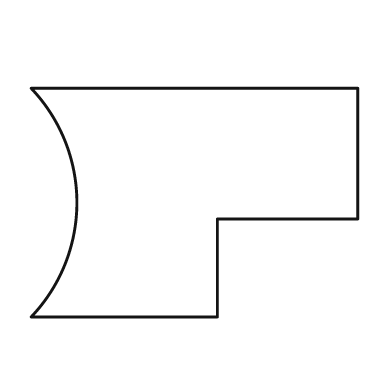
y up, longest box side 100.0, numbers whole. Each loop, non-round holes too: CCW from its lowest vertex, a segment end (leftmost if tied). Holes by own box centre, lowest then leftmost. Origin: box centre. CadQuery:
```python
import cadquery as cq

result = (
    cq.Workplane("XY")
    .moveTo(-50.0, -35.0)
    .lineTo(7.0, -35.0)
    .lineTo(7.0, -5.0)
    .lineTo(50.0, -5.0)
    .lineTo(50.0, 35.0)
    .lineTo(-50.0, 35.0)
    .threePointArc((-36.0, 0.0), (-50.0, -35.0))
    .close()
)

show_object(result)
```